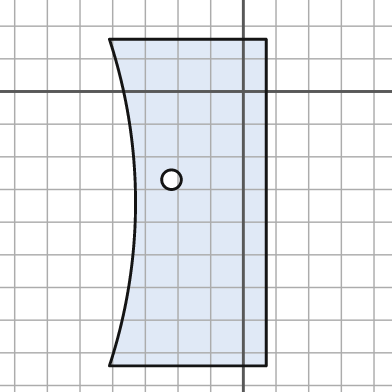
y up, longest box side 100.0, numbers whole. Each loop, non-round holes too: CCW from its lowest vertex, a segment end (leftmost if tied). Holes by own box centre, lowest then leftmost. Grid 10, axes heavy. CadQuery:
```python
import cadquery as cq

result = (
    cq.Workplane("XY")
    .moveTo(-41.0, -84.0)
    .lineTo(7.0, -84.0)
    .lineTo(7.0, 16.0)
    .lineTo(-41.0, 16.0)
    .threePointArc((-33.0, -34.0), (-41.0, -84.0))
    .close()
    .moveTo(-22.0, -27.0)
    .circle(3.0)
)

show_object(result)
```